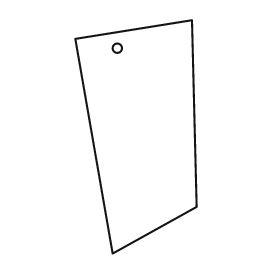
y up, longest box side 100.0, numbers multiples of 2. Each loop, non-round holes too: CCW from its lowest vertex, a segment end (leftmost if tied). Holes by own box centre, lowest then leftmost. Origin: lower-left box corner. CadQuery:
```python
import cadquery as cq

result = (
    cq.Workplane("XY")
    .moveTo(16.0, 0.0)
    .lineTo(52.0, 20.0)
    .lineTo(50.0, 100.0)
    .lineTo(0.0, 92.0)
    .close()
    .moveTo(18.0, 88.0)
    .circle(2.0)
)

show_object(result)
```